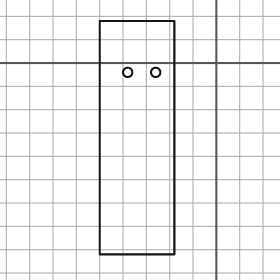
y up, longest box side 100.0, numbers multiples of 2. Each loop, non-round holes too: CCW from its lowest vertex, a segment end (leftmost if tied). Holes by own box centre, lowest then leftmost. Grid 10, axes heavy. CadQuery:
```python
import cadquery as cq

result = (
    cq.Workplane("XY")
    .moveTo(-50.0, -82.0)
    .lineTo(-18.0, -82.0)
    .lineTo(-18.0, 18.0)
    .lineTo(-50.0, 18.0)
    .close()
    .moveTo(-38.0, -4.0)
    .circle(2.0)
    .moveTo(-26.0, -4.0)
    .circle(2.0)
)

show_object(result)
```